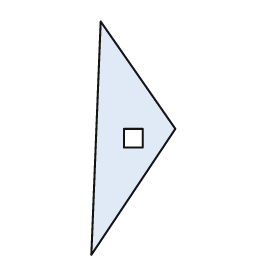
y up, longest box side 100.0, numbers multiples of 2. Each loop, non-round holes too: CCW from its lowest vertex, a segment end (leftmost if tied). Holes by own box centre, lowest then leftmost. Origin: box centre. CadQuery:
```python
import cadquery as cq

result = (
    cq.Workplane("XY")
    .moveTo(-18.0, -50.0)
    .lineTo(18.0, 4.0)
    .lineTo(-14.0, 50.0)
    .close()
    .moveTo(-4.0, -4.0)
    .lineTo(4.0, -4.0)
    .lineTo(4.0, 4.0)
    .lineTo(-4.0, 4.0)
    .close()
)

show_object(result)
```